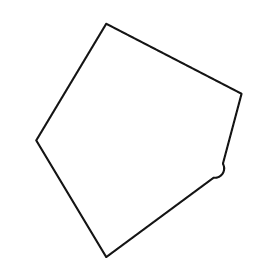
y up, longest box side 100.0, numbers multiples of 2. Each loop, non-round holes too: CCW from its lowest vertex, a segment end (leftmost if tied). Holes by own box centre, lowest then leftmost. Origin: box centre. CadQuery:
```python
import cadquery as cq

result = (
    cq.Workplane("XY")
    .moveTo(-14.0, -50.0)
    .lineTo(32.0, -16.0)
    .threePointArc((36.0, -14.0), (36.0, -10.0))
    .lineTo(44.0, 20.0)
    .lineTo(-14.0, 50.0)
    .lineTo(-44.0, 0.0)
    .close()
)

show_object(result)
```